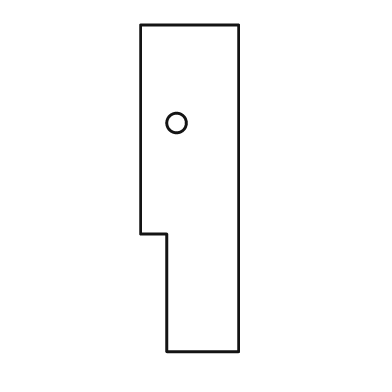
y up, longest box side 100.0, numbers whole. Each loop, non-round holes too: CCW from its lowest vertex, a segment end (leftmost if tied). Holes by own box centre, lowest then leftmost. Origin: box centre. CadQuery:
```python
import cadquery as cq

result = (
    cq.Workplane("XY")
    .moveTo(-7.0, -50.0)
    .lineTo(15.0, -50.0)
    .lineTo(15.0, 50.0)
    .lineTo(-15.0, 50.0)
    .lineTo(-15.0, -14.0)
    .lineTo(-7.0, -14.0)
    .close()
    .moveTo(-4.0, 20.0)
    .circle(3.0)
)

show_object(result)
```